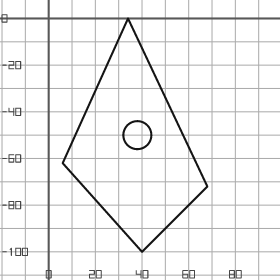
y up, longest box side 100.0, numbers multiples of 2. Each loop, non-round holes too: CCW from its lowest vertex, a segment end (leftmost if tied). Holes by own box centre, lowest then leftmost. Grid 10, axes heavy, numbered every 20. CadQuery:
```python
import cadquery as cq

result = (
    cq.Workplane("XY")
    .moveTo(40.0, -100.0)
    .lineTo(68.0, -72.0)
    .lineTo(34.0, 0.0)
    .lineTo(6.0, -62.0)
    .close()
    .moveTo(38.0, -50.0)
    .circle(6.0)
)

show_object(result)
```